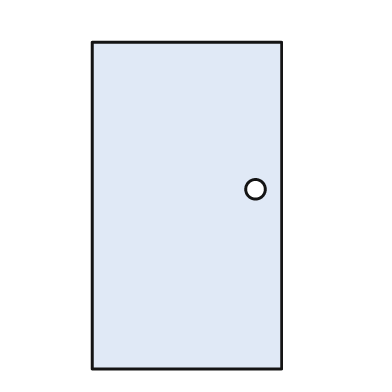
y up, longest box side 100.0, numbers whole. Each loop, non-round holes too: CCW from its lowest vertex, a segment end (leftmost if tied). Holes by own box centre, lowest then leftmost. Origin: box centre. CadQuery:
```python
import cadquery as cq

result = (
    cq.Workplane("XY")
    .moveTo(-29.0, -50.0)
    .lineTo(29.0, -50.0)
    .lineTo(29.0, 50.0)
    .lineTo(-29.0, 50.0)
    .close()
    .moveTo(21.0, 5.0)
    .circle(3.0)
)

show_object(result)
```